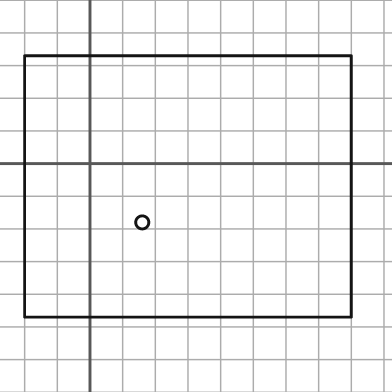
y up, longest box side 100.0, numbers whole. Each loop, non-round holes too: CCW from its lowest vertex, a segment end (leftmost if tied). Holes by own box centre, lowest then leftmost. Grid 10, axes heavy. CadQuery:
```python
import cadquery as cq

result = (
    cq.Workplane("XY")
    .moveTo(-20.0, -47.0)
    .lineTo(80.0, -47.0)
    .lineTo(80.0, 33.0)
    .lineTo(-20.0, 33.0)
    .close()
    .moveTo(16.0, -18.0)
    .circle(2.0)
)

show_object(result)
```